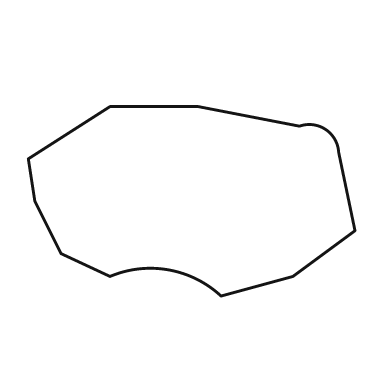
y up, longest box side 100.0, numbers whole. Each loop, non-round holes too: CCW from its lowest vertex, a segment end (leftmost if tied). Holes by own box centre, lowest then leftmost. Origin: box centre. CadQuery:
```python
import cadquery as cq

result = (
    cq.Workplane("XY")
    .moveTo(9.0, -29.0)
    .lineTo(31.0, -23.0)
    .lineTo(50.0, -9.0)
    .lineTo(45.0, 15.0)
    .threePointArc((41.0, 22.0), (33.0, 23.0))
    .lineTo(2.0, 29.0)
    .lineTo(-25.0, 29.0)
    .lineTo(-50.0, 13.0)
    .lineTo(-48.0, 0.0)
    .lineTo(-40.0, -16.0)
    .lineTo(-25.0, -23.0)
    .threePointArc((-7.0, -21.0), (9.0, -29.0))
    .close()
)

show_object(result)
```